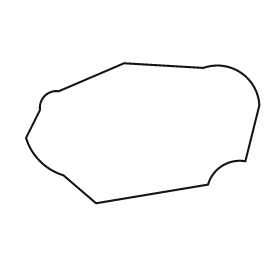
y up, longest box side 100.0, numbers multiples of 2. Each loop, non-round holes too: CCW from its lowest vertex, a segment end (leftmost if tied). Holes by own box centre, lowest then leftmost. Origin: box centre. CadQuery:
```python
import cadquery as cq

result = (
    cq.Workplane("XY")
    .moveTo(-20.0, -30.0)
    .lineTo(28.0, -22.0)
    .threePointArc((34.0, -14.0), (44.0, -12.0))
    .lineTo(50.0, 12.0)
    .threePointArc((42.0, 26.0), (26.0, 28.0))
    .lineTo(-8.0, 30.0)
    .lineTo(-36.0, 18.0)
    .threePointArc((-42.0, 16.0), (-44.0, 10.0))
    .lineTo(-50.0, -2.0)
    .threePointArc((-44.0, -12.0), (-34.0, -18.0))
    .close()
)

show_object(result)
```